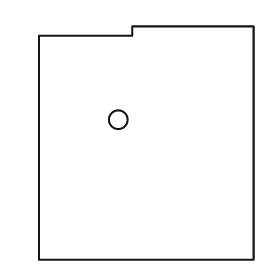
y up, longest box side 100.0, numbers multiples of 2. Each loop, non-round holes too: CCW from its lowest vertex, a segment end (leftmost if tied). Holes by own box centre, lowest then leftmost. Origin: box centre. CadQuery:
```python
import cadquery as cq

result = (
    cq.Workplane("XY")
    .moveTo(-46.0, -50.0)
    .lineTo(46.0, -50.0)
    .lineTo(46.0, 50.0)
    .lineTo(-6.0, 50.0)
    .lineTo(-6.0, 46.0)
    .lineTo(-46.0, 46.0)
    .close()
    .moveTo(-12.0, 10.0)
    .circle(4.0)
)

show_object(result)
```